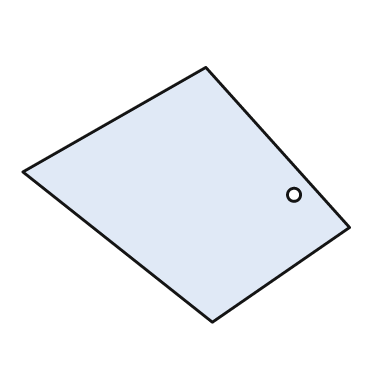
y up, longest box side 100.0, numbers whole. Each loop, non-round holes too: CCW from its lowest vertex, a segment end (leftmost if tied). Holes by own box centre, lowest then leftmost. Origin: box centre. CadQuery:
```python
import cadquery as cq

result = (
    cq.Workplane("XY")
    .moveTo(8.0, -39.0)
    .lineTo(50.0, -10.0)
    .lineTo(6.0, 39.0)
    .lineTo(-50.0, 7.0)
    .close()
    .moveTo(33.0, 0.0)
    .circle(2.0)
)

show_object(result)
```